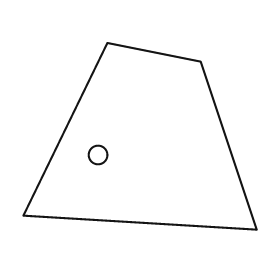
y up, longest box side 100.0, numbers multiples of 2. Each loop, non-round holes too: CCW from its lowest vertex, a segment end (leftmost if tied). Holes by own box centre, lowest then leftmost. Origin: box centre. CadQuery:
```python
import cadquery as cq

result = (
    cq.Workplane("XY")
    .moveTo(50.0, -40.0)
    .lineTo(26.0, 32.0)
    .lineTo(-14.0, 40.0)
    .lineTo(-50.0, -34.0)
    .close()
    .moveTo(-18.0, -8.0)
    .circle(4.0)
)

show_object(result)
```